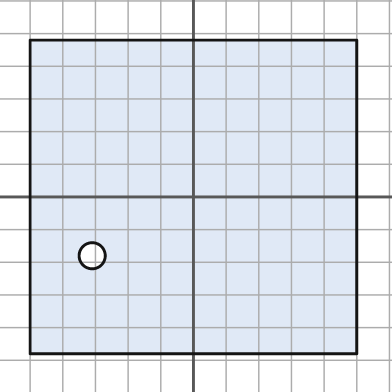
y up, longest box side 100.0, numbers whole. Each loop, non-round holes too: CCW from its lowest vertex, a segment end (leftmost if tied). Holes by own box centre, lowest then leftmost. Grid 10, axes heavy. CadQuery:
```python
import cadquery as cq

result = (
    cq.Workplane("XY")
    .moveTo(-50.0, -48.0)
    .lineTo(50.0, -48.0)
    .lineTo(50.0, 48.0)
    .lineTo(-50.0, 48.0)
    .close()
    .moveTo(-31.0, -18.0)
    .circle(4.0)
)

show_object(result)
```